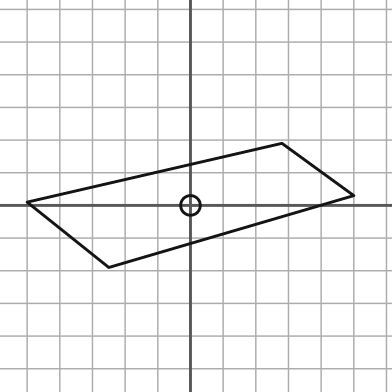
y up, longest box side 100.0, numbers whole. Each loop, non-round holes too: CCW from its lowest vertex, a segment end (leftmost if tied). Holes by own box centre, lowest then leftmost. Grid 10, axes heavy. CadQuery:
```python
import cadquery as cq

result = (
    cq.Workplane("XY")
    .moveTo(-25.0, -19.0)
    .lineTo(50.0, 3.0)
    .lineTo(28.0, 19.0)
    .lineTo(-50.0, 1.0)
    .close()
    .moveTo(0.0, 0.0)
    .circle(3.0)
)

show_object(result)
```